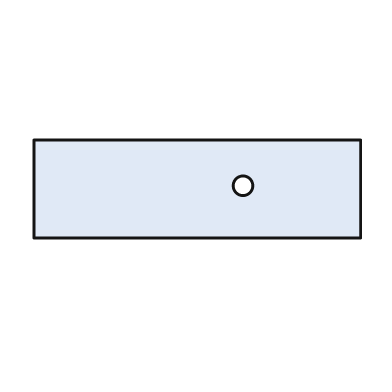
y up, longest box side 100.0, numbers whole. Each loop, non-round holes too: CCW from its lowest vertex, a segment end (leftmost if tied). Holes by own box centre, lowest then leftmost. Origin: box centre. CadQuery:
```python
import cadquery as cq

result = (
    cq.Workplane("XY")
    .moveTo(-50.0, -15.0)
    .lineTo(50.0, -15.0)
    .lineTo(50.0, 15.0)
    .lineTo(-50.0, 15.0)
    .close()
    .moveTo(14.0, 1.0)
    .circle(3.0)
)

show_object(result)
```